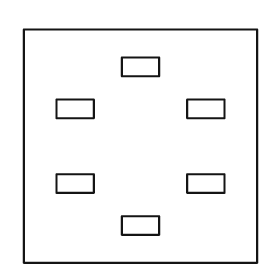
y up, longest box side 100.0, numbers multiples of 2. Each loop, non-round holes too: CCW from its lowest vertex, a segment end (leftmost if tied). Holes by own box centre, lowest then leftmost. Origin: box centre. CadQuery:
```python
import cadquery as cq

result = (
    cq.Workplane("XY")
    .moveTo(-50.0, -50.0)
    .lineTo(50.0, -50.0)
    .lineTo(50.0, 50.0)
    .lineTo(-50.0, 50.0)
    .close()
    .moveTo(-8.0, -38.0)
    .lineTo(8.0, -38.0)
    .lineTo(8.0, -30.0)
    .lineTo(-8.0, -30.0)
    .close()
    .moveTo(-36.0, -20.0)
    .lineTo(-20.0, -20.0)
    .lineTo(-20.0, -12.0)
    .lineTo(-36.0, -12.0)
    .close()
    .moveTo(20.0, -20.0)
    .lineTo(36.0, -20.0)
    .lineTo(36.0, -12.0)
    .lineTo(20.0, -12.0)
    .close()
    .moveTo(-36.0, 12.0)
    .lineTo(-20.0, 12.0)
    .lineTo(-20.0, 20.0)
    .lineTo(-36.0, 20.0)
    .close()
    .moveTo(20.0, 12.0)
    .lineTo(36.0, 12.0)
    .lineTo(36.0, 20.0)
    .lineTo(20.0, 20.0)
    .close()
    .moveTo(-8.0, 30.0)
    .lineTo(8.0, 30.0)
    .lineTo(8.0, 38.0)
    .lineTo(-8.0, 38.0)
    .close()
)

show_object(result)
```